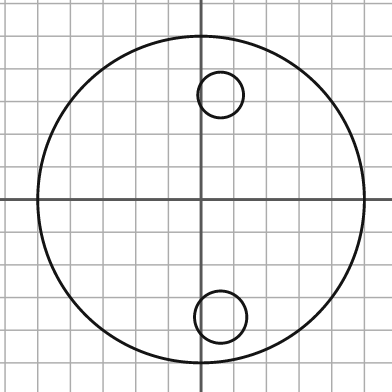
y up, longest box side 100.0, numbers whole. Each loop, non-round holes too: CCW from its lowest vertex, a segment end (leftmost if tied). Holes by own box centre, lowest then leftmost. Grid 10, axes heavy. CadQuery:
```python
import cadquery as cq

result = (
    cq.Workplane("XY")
    .moveTo(0.0, 0.0)
    .circle(50.0)
    .moveTo(6.0, -36.0)
    .circle(8.0)
    .moveTo(6.0, 32.0)
    .circle(7.0)
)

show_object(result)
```